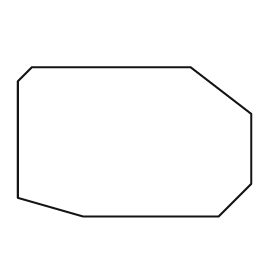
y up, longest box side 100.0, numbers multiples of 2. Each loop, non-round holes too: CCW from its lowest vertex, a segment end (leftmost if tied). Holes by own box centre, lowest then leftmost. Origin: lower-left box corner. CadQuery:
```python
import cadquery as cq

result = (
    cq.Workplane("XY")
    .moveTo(28.0, 0.0)
    .lineTo(86.0, 0.0)
    .lineTo(100.0, 14.0)
    .lineTo(100.0, 44.0)
    .lineTo(74.0, 64.0)
    .lineTo(6.0, 64.0)
    .lineTo(0.0, 58.0)
    .lineTo(0.0, 8.0)
    .close()
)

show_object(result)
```